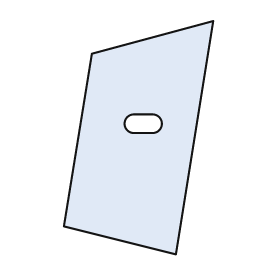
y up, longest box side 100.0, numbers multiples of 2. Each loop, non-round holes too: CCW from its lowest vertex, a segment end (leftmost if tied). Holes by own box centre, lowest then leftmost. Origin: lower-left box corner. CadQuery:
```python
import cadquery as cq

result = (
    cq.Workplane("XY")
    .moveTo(48.0, 0.0)
    .lineTo(64.0, 100.0)
    .lineTo(12.0, 86.0)
    .lineTo(0.0, 12.0)
    .close()
    .moveTo(30.0, 52.0)
    .lineTo(38.0, 52.0)
    .threePointArc((42.0, 56.0), (38.0, 60.0))
    .lineTo(30.0, 60.0)
    .threePointArc((26.0, 56.0), (30.0, 52.0))
    .close()
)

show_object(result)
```